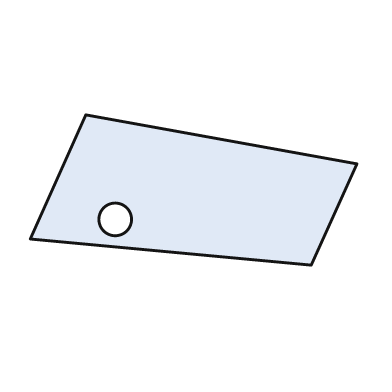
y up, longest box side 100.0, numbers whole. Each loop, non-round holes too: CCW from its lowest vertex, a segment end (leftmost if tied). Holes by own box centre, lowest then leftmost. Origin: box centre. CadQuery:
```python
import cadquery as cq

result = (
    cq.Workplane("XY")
    .moveTo(36.0, -23.0)
    .lineTo(50.0, 8.0)
    .lineTo(-33.0, 23.0)
    .lineTo(-50.0, -15.0)
    .close()
    .moveTo(-24.0, -9.0)
    .circle(5.0)
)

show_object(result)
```